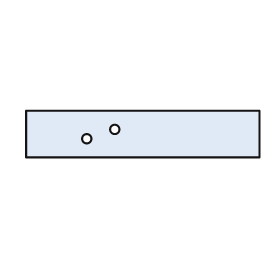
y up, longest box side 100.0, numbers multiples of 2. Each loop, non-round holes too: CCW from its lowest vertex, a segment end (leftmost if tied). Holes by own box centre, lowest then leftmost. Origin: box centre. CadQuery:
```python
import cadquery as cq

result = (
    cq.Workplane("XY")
    .moveTo(-50.0, -10.0)
    .lineTo(50.0, -10.0)
    .lineTo(50.0, 10.0)
    .lineTo(-50.0, 10.0)
    .close()
    .moveTo(-24.0, -2.0)
    .circle(2.0)
    .moveTo(-12.0, 2.0)
    .circle(2.0)
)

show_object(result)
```